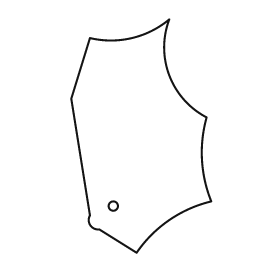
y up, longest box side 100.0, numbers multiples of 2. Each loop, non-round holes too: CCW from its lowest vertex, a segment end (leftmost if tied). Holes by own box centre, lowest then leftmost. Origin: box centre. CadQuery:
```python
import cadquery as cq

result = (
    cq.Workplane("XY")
    .moveTo(-2.0, -50.0)
    .threePointArc((12.0, -36.0), (30.0, -28.0))
    .threePointArc((26.0, -10.0), (28.0, 8.0))
    .threePointArc((12.0, 26.0), (12.0, 50.0))
    .threePointArc((-4.0, 42.0), (-22.0, 42.0))
    .lineTo(-30.0, 16.0)
    .lineTo(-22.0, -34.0)
    .threePointArc((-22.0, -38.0), (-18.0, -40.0))
    .close()
    .moveTo(-12.0, -30.0)
    .circle(2.0)
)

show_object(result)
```